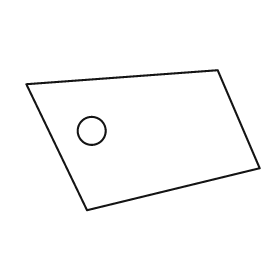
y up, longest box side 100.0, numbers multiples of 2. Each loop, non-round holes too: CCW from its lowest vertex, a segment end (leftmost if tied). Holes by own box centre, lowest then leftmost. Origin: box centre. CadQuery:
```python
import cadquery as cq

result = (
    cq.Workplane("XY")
    .moveTo(-24.0, -30.0)
    .lineTo(50.0, -12.0)
    .lineTo(32.0, 30.0)
    .lineTo(-50.0, 24.0)
    .close()
    .moveTo(-22.0, 4.0)
    .circle(6.0)
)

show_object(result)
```